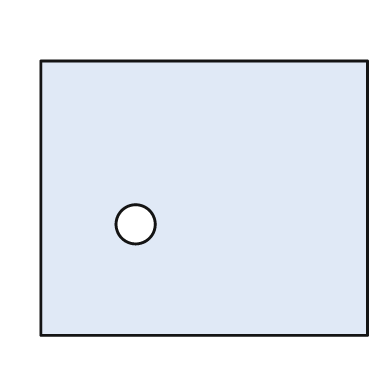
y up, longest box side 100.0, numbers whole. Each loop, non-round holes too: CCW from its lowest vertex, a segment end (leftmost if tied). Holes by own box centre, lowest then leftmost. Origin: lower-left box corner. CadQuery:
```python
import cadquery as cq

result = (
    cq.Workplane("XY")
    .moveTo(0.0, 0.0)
    .lineTo(100.0, 0.0)
    .lineTo(100.0, 84.0)
    .lineTo(0.0, 84.0)
    .close()
    .moveTo(29.0, 34.0)
    .circle(6.0)
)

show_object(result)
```